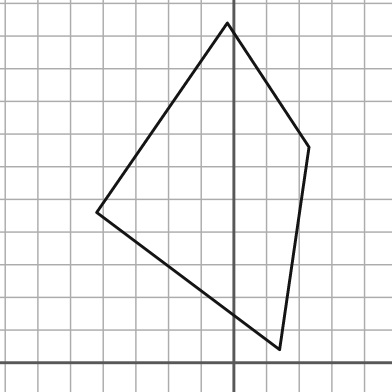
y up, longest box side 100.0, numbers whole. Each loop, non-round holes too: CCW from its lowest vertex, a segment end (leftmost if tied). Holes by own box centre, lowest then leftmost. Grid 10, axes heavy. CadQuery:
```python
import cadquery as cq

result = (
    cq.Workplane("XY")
    .moveTo(14.0, 4.0)
    .lineTo(23.0, 66.0)
    .lineTo(-2.0, 104.0)
    .lineTo(-42.0, 46.0)
    .close()
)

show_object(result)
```